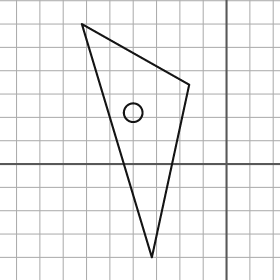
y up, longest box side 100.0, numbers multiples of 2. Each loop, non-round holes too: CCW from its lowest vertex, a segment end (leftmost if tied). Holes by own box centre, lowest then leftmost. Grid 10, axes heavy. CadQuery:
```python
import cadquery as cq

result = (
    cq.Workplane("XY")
    .moveTo(-32.0, -40.0)
    .lineTo(-16.0, 34.0)
    .lineTo(-62.0, 60.0)
    .close()
    .moveTo(-40.0, 22.0)
    .circle(4.0)
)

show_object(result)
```